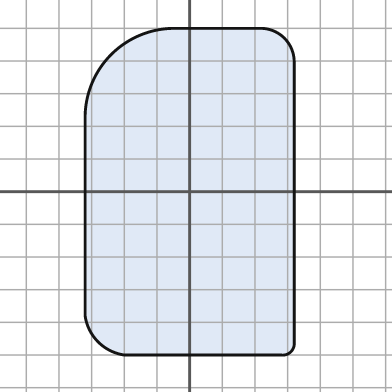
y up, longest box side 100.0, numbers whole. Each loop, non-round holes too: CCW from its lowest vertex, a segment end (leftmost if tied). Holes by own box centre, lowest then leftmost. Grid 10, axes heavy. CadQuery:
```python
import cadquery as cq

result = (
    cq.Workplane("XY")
    .moveTo(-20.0, -50.0)
    .lineTo(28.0, -50.0)
    .threePointArc((31.0, -49.0), (32.0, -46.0))
    .lineTo(32.0, 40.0)
    .threePointArc((29.0, 47.0), (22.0, 50.0))
    .lineTo(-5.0, 50.0)
    .threePointArc((-24.0, 42.0), (-32.0, 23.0))
    .lineTo(-32.0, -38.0)
    .threePointArc((-28.0, -46.0), (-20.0, -50.0))
    .close()
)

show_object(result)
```